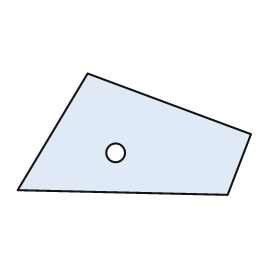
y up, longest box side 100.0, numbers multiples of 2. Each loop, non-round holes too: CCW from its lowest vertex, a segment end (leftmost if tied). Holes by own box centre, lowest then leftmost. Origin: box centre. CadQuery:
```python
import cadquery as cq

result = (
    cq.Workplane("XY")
    .moveTo(40.0, -26.0)
    .lineTo(50.0, 0.0)
    .lineTo(-20.0, 26.0)
    .lineTo(-50.0, -24.0)
    .close()
    .moveTo(-8.0, -8.0)
    .circle(4.0)
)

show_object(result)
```